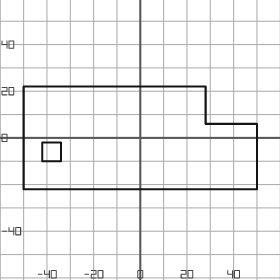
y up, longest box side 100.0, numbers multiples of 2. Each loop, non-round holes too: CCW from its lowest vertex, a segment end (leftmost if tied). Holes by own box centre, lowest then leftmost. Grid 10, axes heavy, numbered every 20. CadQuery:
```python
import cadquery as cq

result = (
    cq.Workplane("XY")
    .moveTo(-50.0, -22.0)
    .lineTo(50.0, -22.0)
    .lineTo(50.0, 6.0)
    .lineTo(28.0, 6.0)
    .lineTo(28.0, 22.0)
    .lineTo(-50.0, 22.0)
    .close()
    .moveTo(-42.0, -10.0)
    .lineTo(-34.0, -10.0)
    .lineTo(-34.0, -2.0)
    .lineTo(-42.0, -2.0)
    .close()
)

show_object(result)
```